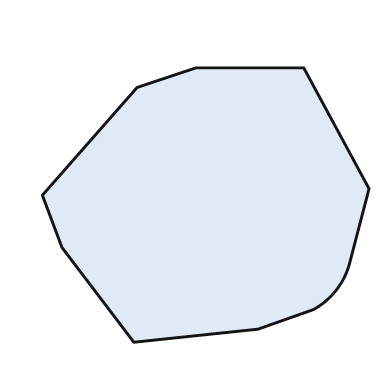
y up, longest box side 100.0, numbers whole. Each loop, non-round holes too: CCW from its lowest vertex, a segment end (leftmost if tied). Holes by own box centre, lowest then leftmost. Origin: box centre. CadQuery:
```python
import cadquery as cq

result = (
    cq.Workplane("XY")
    .moveTo(-22.0, -42.0)
    .lineTo(16.0, -38.0)
    .lineTo(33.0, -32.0)
    .threePointArc((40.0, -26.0), (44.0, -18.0))
    .lineTo(50.0, 5.0)
    .lineTo(30.0, 42.0)
    .lineTo(-3.0, 42.0)
    .lineTo(-21.0, 36.0)
    .lineTo(-50.0, 3.0)
    .lineTo(-44.0, -13.0)
    .close()
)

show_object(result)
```